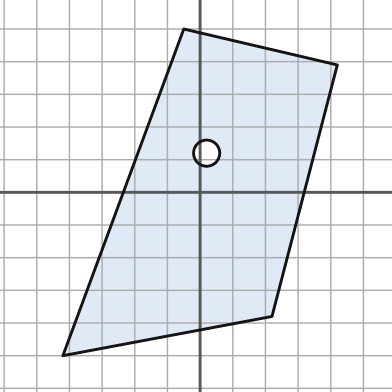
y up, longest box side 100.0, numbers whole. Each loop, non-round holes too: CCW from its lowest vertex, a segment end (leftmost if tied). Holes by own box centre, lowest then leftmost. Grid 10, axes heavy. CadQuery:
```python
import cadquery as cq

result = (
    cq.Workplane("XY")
    .moveTo(-42.0, -50.0)
    .lineTo(22.0, -38.0)
    .lineTo(42.0, 39.0)
    .lineTo(-5.0, 50.0)
    .close()
    .moveTo(2.0, 12.0)
    .circle(4.0)
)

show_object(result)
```